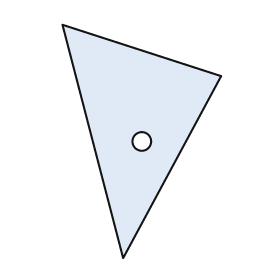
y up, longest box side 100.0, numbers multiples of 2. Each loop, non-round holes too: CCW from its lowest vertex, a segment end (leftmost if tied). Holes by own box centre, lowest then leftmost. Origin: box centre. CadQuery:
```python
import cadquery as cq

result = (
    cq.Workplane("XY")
    .moveTo(-8.0, -50.0)
    .lineTo(34.0, 28.0)
    .lineTo(-34.0, 50.0)
    .close()
    .moveTo(0.0, 0.0)
    .circle(4.0)
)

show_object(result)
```